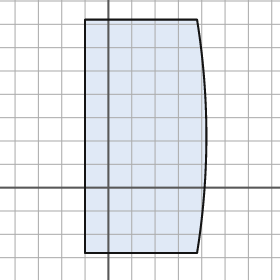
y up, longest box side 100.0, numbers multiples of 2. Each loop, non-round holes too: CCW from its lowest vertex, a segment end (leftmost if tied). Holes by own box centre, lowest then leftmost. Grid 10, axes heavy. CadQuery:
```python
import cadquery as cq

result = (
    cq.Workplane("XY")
    .moveTo(-10.0, -28.0)
    .lineTo(38.0, -28.0)
    .threePointArc((42.0, 22.0), (38.0, 72.0))
    .lineTo(-10.0, 72.0)
    .close()
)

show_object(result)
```